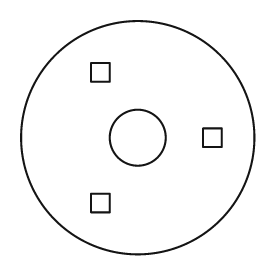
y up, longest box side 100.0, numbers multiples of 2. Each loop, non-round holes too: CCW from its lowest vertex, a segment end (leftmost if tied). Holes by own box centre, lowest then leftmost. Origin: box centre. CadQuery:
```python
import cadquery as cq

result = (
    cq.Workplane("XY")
    .moveTo(0.0, 0.0)
    .circle(50.0)
    .moveTo(-20.0, -32.0)
    .lineTo(-12.0, -32.0)
    .lineTo(-12.0, -24.0)
    .lineTo(-20.0, -24.0)
    .close()
    .moveTo(0.0, 0.0)
    .circle(12.0)
    .moveTo(28.0, -4.0)
    .lineTo(36.0, -4.0)
    .lineTo(36.0, 4.0)
    .lineTo(28.0, 4.0)
    .close()
    .moveTo(-20.0, 24.0)
    .lineTo(-12.0, 24.0)
    .lineTo(-12.0, 32.0)
    .lineTo(-20.0, 32.0)
    .close()
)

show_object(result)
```